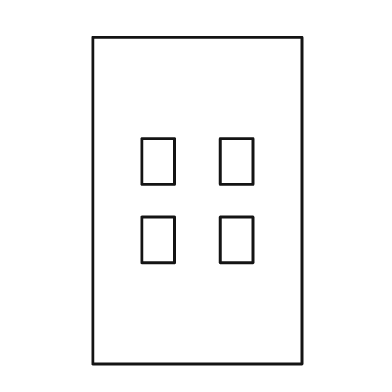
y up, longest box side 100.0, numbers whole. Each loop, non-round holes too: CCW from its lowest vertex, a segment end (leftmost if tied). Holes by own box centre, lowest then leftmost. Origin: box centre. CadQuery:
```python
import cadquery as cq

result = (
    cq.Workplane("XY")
    .moveTo(-32.0, -50.0)
    .lineTo(32.0, -50.0)
    .lineTo(32.0, 50.0)
    .lineTo(-32.0, 50.0)
    .close()
    .moveTo(-17.0, -19.0)
    .lineTo(-7.0, -19.0)
    .lineTo(-7.0, -5.0)
    .lineTo(-17.0, -5.0)
    .close()
    .moveTo(7.0, -19.0)
    .lineTo(17.0, -19.0)
    .lineTo(17.0, -5.0)
    .lineTo(7.0, -5.0)
    .close()
    .moveTo(-17.0, 5.0)
    .lineTo(-7.0, 5.0)
    .lineTo(-7.0, 19.0)
    .lineTo(-17.0, 19.0)
    .close()
    .moveTo(7.0, 5.0)
    .lineTo(17.0, 5.0)
    .lineTo(17.0, 19.0)
    .lineTo(7.0, 19.0)
    .close()
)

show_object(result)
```